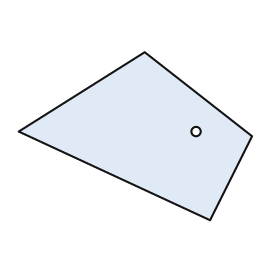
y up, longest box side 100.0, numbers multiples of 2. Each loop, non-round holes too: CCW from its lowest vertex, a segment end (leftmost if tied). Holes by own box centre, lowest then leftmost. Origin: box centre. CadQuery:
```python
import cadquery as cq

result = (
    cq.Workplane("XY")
    .moveTo(32.0, -36.0)
    .lineTo(50.0, 0.0)
    .lineTo(4.0, 36.0)
    .lineTo(-50.0, 2.0)
    .close()
    .moveTo(26.0, 2.0)
    .circle(2.0)
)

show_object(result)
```